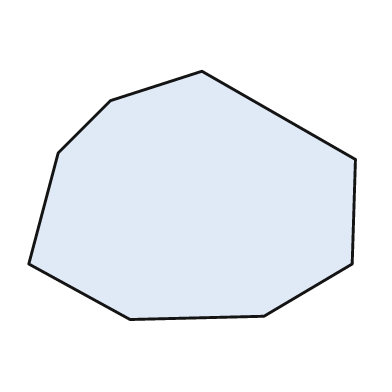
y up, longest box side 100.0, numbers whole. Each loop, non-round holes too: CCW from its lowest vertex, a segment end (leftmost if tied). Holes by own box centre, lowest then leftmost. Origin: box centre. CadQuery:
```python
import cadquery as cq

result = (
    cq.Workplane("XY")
    .moveTo(-19.0, -38.0)
    .lineTo(22.0, -37.0)
    .lineTo(49.0, -21.0)
    .lineTo(50.0, 11.0)
    .lineTo(3.0, 38.0)
    .lineTo(-25.0, 29.0)
    .lineTo(-41.0, 13.0)
    .lineTo(-50.0, -21.0)
    .close()
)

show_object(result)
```